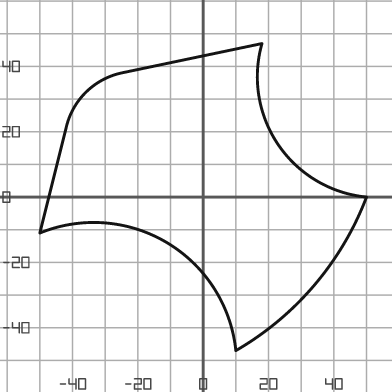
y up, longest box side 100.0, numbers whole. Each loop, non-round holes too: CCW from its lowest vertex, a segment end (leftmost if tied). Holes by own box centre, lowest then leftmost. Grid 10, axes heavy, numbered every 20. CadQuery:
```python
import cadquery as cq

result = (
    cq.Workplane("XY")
    .moveTo(10.0, -47.0)
    .threePointArc((34.0, -27.0), (50.0, 0.0))
    .threePointArc((23.0, 16.0), (18.0, 47.0))
    .lineTo(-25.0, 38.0)
    .threePointArc((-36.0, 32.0), (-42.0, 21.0))
    .lineTo(-50.0, -11.0)
    .threePointArc((-11.0, -14.0), (10.0, -47.0))
    .close()
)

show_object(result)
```